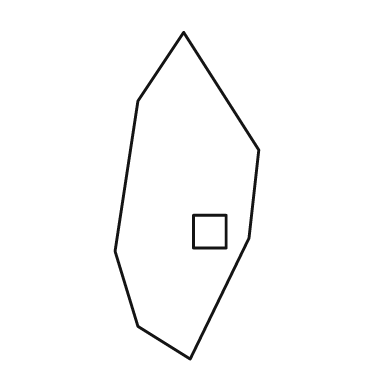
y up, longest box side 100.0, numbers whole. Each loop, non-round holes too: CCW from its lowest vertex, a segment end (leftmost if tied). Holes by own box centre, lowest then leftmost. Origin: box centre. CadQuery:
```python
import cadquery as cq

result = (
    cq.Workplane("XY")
    .moveTo(1.0, -50.0)
    .lineTo(19.0, -13.0)
    .lineTo(22.0, 14.0)
    .lineTo(-1.0, 50.0)
    .lineTo(-15.0, 29.0)
    .lineTo(-22.0, -17.0)
    .lineTo(-15.0, -40.0)
    .close()
    .moveTo(2.0, -16.0)
    .lineTo(12.0, -16.0)
    .lineTo(12.0, -6.0)
    .lineTo(2.0, -6.0)
    .close()
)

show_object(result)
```